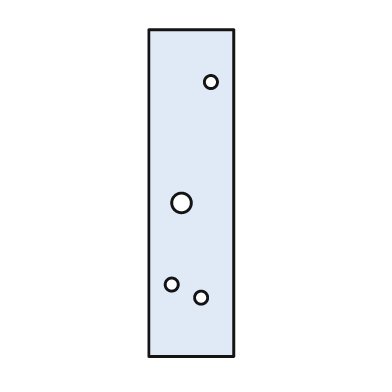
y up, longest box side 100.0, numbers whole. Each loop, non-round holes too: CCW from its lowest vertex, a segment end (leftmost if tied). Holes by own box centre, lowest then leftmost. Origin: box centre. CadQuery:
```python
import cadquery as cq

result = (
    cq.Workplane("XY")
    .moveTo(-13.0, -50.0)
    .lineTo(13.0, -50.0)
    .lineTo(13.0, 50.0)
    .lineTo(-13.0, 50.0)
    .close()
    .moveTo(3.0, -32.0)
    .circle(2.0)
    .moveTo(-6.0, -28.0)
    .circle(2.0)
    .moveTo(-3.0, -3.0)
    .circle(3.0)
    .moveTo(6.0, 34.0)
    .circle(2.0)
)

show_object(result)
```